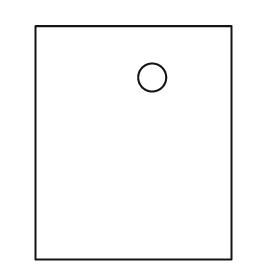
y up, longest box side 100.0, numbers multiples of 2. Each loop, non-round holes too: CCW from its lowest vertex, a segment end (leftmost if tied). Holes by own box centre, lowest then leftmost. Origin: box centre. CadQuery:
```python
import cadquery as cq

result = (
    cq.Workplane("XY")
    .moveTo(-42.0, -50.0)
    .lineTo(42.0, -50.0)
    .lineTo(42.0, 50.0)
    .lineTo(-42.0, 50.0)
    .close()
    .moveTo(8.0, 28.0)
    .circle(6.0)
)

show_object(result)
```